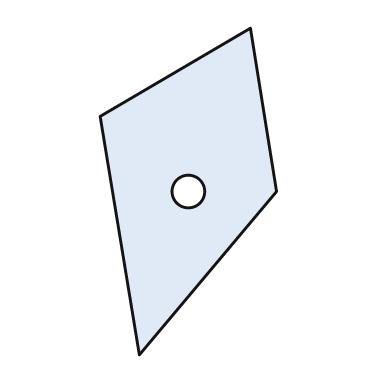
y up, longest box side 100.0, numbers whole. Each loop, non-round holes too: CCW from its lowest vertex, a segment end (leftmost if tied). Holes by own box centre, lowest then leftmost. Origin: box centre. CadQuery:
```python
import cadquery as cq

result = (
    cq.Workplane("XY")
    .moveTo(-15.0, -50.0)
    .lineTo(27.0, 0.0)
    .lineTo(19.0, 50.0)
    .lineTo(-27.0, 23.0)
    .close()
    .moveTo(0.0, 0.0)
    .circle(5.0)
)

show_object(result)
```